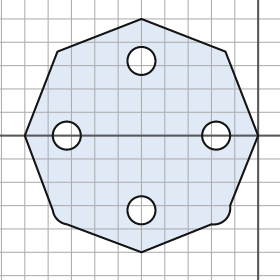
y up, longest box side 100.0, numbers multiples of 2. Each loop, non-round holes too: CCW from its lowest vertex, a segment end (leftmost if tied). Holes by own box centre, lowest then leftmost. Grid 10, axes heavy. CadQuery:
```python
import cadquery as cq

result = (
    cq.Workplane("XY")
    .moveTo(-50.0, -50.0)
    .lineTo(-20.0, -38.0)
    .threePointArc((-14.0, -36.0), (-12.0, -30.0))
    .lineTo(0.0, 0.0)
    .lineTo(-14.0, 36.0)
    .lineTo(-50.0, 50.0)
    .lineTo(-86.0, 36.0)
    .lineTo(-100.0, 0.0)
    .lineTo(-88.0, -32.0)
    .threePointArc((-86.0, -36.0), (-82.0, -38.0))
    .close()
    .moveTo(-50.0, -32.0)
    .circle(6.0)
    .moveTo(-82.0, 0.0)
    .circle(6.0)
    .moveTo(-18.0, 0.0)
    .circle(6.0)
    .moveTo(-50.0, 32.0)
    .circle(6.0)
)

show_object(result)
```